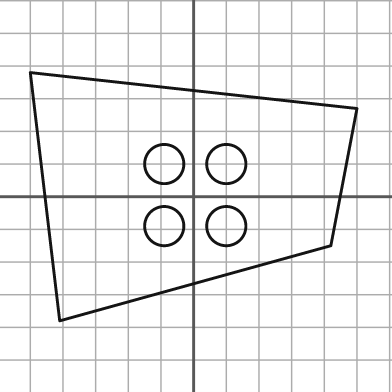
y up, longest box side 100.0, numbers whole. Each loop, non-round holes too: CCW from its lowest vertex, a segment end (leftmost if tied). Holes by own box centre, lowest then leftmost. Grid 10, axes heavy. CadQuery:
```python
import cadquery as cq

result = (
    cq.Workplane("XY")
    .moveTo(-41.0, -38.0)
    .lineTo(42.0, -15.0)
    .lineTo(50.0, 27.0)
    .lineTo(-50.0, 38.0)
    .close()
    .moveTo(-9.0, -9.0)
    .circle(6.0)
    .moveTo(10.0, -9.0)
    .circle(6.0)
    .moveTo(-9.0, 10.0)
    .circle(6.0)
    .moveTo(10.0, 10.0)
    .circle(6.0)
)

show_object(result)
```